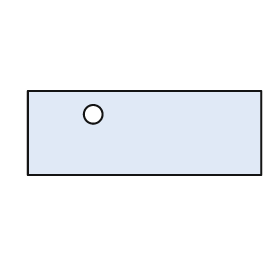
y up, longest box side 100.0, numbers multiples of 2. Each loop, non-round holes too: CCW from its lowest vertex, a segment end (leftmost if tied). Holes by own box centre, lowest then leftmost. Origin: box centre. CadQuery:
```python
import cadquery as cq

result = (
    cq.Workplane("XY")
    .moveTo(-50.0, -18.0)
    .lineTo(50.0, -18.0)
    .lineTo(50.0, 18.0)
    .lineTo(-50.0, 18.0)
    .close()
    .moveTo(-22.0, 8.0)
    .circle(4.0)
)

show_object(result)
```